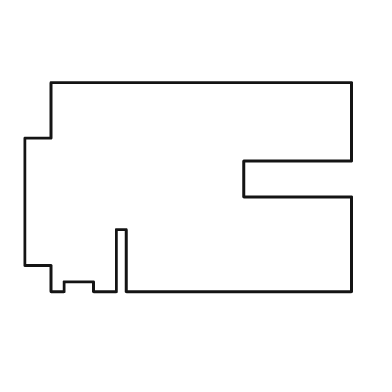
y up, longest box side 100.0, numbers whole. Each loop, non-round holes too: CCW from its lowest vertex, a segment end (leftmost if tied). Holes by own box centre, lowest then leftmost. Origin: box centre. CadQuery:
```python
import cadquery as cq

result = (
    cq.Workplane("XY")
    .moveTo(-42.0, -32.0)
    .lineTo(-38.0, -32.0)
    .lineTo(-38.0, -29.0)
    .lineTo(-29.0, -29.0)
    .lineTo(-29.0, -32.0)
    .lineTo(-22.0, -32.0)
    .lineTo(-22.0, -13.0)
    .lineTo(-19.0, -13.0)
    .lineTo(-19.0, -32.0)
    .lineTo(50.0, -32.0)
    .lineTo(50.0, -3.0)
    .lineTo(17.0, -3.0)
    .lineTo(17.0, 8.0)
    .lineTo(50.0, 8.0)
    .lineTo(50.0, 32.0)
    .lineTo(-42.0, 32.0)
    .lineTo(-42.0, 15.0)
    .lineTo(-50.0, 15.0)
    .lineTo(-50.0, -24.0)
    .lineTo(-42.0, -24.0)
    .close()
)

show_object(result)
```